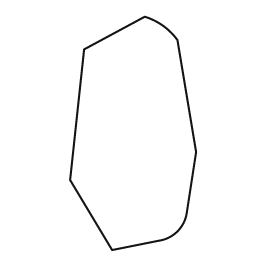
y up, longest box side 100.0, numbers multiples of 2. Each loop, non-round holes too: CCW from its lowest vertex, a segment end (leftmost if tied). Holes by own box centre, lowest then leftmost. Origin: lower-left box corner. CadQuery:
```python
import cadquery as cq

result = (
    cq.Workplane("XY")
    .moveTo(18.0, 0.0)
    .lineTo(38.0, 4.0)
    .threePointArc((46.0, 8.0), (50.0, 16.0))
    .lineTo(54.0, 42.0)
    .lineTo(46.0, 90.0)
    .threePointArc((40.0, 96.0), (32.0, 100.0))
    .lineTo(6.0, 86.0)
    .lineTo(0.0, 30.0)
    .close()
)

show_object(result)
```